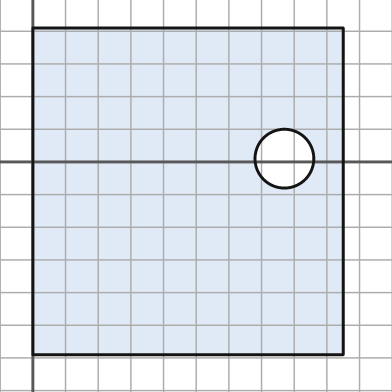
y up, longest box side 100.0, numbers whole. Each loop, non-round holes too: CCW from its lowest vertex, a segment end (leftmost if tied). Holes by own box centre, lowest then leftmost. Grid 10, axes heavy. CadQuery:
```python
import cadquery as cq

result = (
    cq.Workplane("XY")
    .moveTo(0.0, -59.0)
    .lineTo(95.0, -59.0)
    .lineTo(95.0, 41.0)
    .lineTo(0.0, 41.0)
    .close()
    .moveTo(77.0, 1.0)
    .circle(9.0)
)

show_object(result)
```